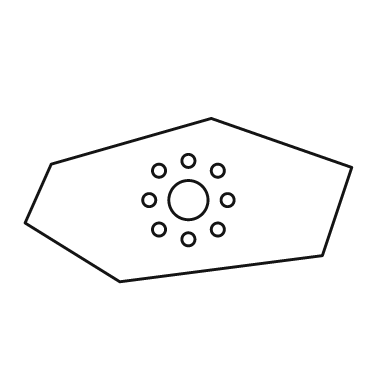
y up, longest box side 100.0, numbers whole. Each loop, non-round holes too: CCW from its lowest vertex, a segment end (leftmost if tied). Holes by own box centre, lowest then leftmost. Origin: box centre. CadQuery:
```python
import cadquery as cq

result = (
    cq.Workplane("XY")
    .moveTo(-21.0, -25.0)
    .lineTo(41.0, -17.0)
    .lineTo(50.0, 10.0)
    .lineTo(7.0, 25.0)
    .lineTo(-42.0, 11.0)
    .lineTo(-50.0, -7.0)
    .close()
    .moveTo(0.0, -12.0)
    .circle(2.0)
    .moveTo(-9.0, -9.0)
    .circle(2.0)
    .moveTo(9.0, -9.0)
    .circle(2.0)
    .moveTo(-12.0, 0.0)
    .circle(2.0)
    .moveTo(0.0, 0.0)
    .circle(6.0)
    .moveTo(12.0, 0.0)
    .circle(2.0)
    .moveTo(-9.0, 9.0)
    .circle(2.0)
    .moveTo(9.0, 9.0)
    .circle(2.0)
    .moveTo(0.0, 12.0)
    .circle(2.0)
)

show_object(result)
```